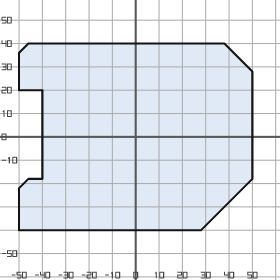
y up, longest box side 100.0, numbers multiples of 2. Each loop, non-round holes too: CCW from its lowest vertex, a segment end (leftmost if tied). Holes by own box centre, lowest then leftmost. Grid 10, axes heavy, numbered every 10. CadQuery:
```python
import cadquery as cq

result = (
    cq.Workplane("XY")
    .moveTo(-50.0, -40.0)
    .lineTo(28.0, -40.0)
    .lineTo(50.0, -18.0)
    .lineTo(50.0, 28.0)
    .lineTo(38.0, 40.0)
    .lineTo(-46.0, 40.0)
    .lineTo(-50.0, 36.0)
    .lineTo(-50.0, 20.0)
    .lineTo(-40.0, 20.0)
    .lineTo(-40.0, -18.0)
    .lineTo(-46.0, -18.0)
    .lineTo(-50.0, -22.0)
    .close()
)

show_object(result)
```